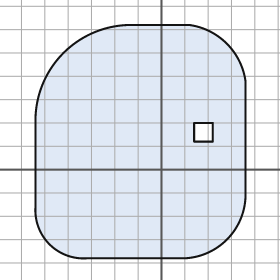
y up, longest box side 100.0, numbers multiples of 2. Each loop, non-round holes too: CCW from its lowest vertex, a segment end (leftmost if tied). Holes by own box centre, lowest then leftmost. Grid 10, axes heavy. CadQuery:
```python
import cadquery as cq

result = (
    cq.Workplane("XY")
    .moveTo(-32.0, -38.0)
    .lineTo(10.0, -38.0)
    .threePointArc((28.0, -30.0), (36.0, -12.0))
    .lineTo(36.0, 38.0)
    .threePointArc((28.0, 54.0), (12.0, 62.0))
    .lineTo(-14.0, 62.0)
    .threePointArc((-42.0, 50.0), (-54.0, 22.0))
    .lineTo(-54.0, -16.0)
    .threePointArc((-48.0, -32.0), (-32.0, -38.0))
    .close()
    .moveTo(14.0, 12.0)
    .lineTo(22.0, 12.0)
    .lineTo(22.0, 20.0)
    .lineTo(14.0, 20.0)
    .close()
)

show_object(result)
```